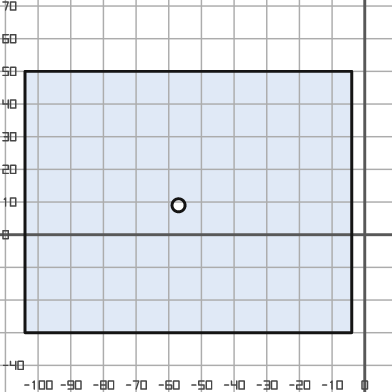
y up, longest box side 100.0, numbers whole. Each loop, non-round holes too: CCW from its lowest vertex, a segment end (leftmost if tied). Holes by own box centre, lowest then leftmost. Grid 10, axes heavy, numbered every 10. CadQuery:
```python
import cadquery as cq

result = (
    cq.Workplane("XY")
    .moveTo(-104.0, -30.0)
    .lineTo(-4.0, -30.0)
    .lineTo(-4.0, 50.0)
    .lineTo(-104.0, 50.0)
    .close()
    .moveTo(-57.0, 9.0)
    .circle(2.0)
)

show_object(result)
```